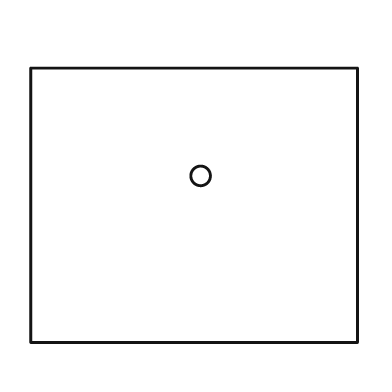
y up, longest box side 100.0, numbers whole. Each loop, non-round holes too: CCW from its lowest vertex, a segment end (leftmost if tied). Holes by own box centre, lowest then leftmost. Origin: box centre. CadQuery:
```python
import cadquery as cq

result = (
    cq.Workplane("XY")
    .moveTo(-50.0, -42.0)
    .lineTo(50.0, -42.0)
    .lineTo(50.0, 42.0)
    .lineTo(-50.0, 42.0)
    .close()
    .moveTo(2.0, 9.0)
    .circle(3.0)
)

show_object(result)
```